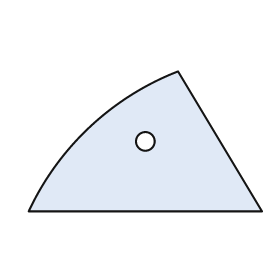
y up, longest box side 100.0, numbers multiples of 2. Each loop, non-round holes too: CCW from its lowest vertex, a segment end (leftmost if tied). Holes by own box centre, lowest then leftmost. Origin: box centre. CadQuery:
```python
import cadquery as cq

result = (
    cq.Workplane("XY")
    .moveTo(-50.0, -30.0)
    .lineTo(50.0, -30.0)
    .lineTo(14.0, 30.0)
    .threePointArc((-24.0, 6.0), (-50.0, -30.0))
    .close()
    .moveTo(0.0, 0.0)
    .circle(4.0)
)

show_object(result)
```